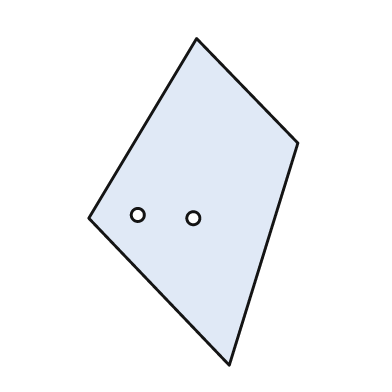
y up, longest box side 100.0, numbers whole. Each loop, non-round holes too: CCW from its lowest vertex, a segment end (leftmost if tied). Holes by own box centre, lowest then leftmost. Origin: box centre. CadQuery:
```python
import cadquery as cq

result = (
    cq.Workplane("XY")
    .moveTo(11.0, -50.0)
    .lineTo(32.0, 18.0)
    .lineTo(1.0, 50.0)
    .lineTo(-32.0, -5.0)
    .close()
    .moveTo(0.0, -5.0)
    .circle(2.0)
    .moveTo(-17.0, -4.0)
    .circle(2.0)
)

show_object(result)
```